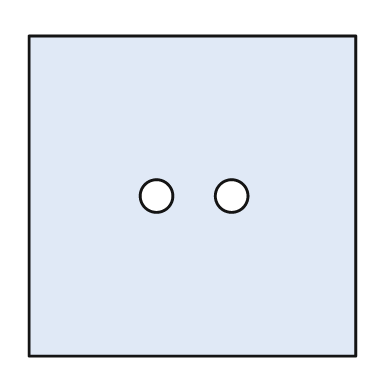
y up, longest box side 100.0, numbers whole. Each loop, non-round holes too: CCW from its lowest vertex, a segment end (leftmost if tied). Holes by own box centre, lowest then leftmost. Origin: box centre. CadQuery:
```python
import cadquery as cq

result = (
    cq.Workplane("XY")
    .moveTo(-50.0, -49.0)
    .lineTo(50.0, -49.0)
    .lineTo(50.0, 49.0)
    .lineTo(-50.0, 49.0)
    .close()
    .moveTo(-11.0, 0.0)
    .circle(5.0)
    .moveTo(12.0, 0.0)
    .circle(5.0)
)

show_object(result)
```